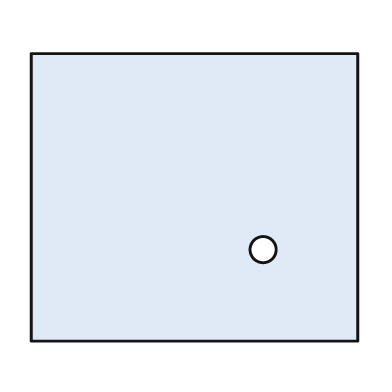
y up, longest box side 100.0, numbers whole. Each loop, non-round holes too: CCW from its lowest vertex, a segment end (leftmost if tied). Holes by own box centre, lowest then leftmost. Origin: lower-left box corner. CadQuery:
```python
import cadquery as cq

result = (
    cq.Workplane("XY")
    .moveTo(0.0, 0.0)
    .lineTo(100.0, 0.0)
    .lineTo(100.0, 88.0)
    .lineTo(0.0, 88.0)
    .close()
    .moveTo(71.0, 28.0)
    .circle(4.0)
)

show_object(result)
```